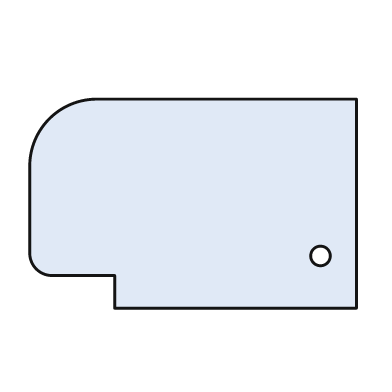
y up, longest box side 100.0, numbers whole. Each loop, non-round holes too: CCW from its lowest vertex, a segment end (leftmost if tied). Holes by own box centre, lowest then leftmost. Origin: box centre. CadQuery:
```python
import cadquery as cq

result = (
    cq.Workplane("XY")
    .moveTo(-24.0, -32.0)
    .lineTo(50.0, -32.0)
    .lineTo(50.0, 32.0)
    .lineTo(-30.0, 32.0)
    .threePointArc((-44.0, 26.0), (-50.0, 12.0))
    .lineTo(-50.0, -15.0)
    .threePointArc((-48.0, -20.0), (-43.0, -22.0))
    .lineTo(-24.0, -22.0)
    .close()
    .moveTo(39.0, -16.0)
    .circle(3.0)
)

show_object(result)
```